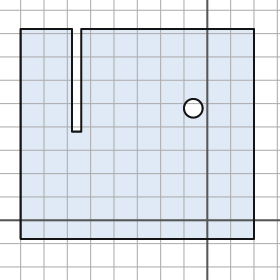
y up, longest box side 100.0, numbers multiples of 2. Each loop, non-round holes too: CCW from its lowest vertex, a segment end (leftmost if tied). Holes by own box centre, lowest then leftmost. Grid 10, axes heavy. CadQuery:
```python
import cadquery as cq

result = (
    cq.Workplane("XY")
    .moveTo(-80.0, -8.0)
    .lineTo(20.0, -8.0)
    .lineTo(20.0, 82.0)
    .lineTo(-54.0, 82.0)
    .lineTo(-54.0, 38.0)
    .lineTo(-58.0, 38.0)
    .lineTo(-58.0, 82.0)
    .lineTo(-80.0, 82.0)
    .close()
    .moveTo(-6.0, 48.0)
    .circle(4.0)
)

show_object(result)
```